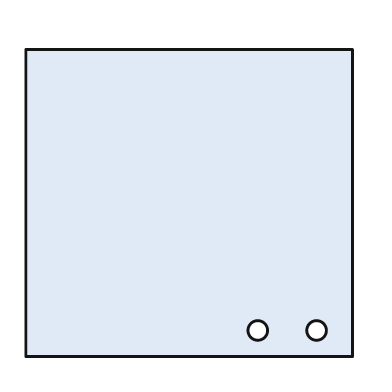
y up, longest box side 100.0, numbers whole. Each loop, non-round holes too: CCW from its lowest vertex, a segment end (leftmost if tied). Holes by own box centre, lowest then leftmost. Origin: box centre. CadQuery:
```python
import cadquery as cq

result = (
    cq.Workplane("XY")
    .moveTo(-50.0, -47.0)
    .lineTo(50.0, -47.0)
    .lineTo(50.0, 47.0)
    .lineTo(-50.0, 47.0)
    .close()
    .moveTo(21.0, -39.0)
    .circle(3.0)
    .moveTo(39.0, -39.0)
    .circle(3.0)
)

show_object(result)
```